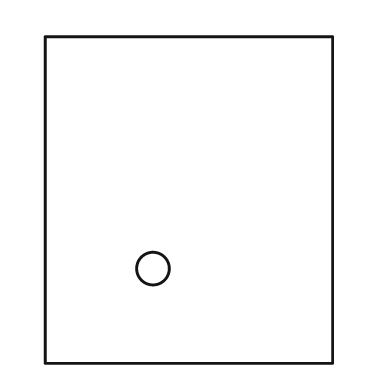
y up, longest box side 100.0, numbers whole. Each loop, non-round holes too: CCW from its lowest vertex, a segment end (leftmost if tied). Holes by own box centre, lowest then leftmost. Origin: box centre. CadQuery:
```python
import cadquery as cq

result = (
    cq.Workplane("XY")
    .moveTo(-44.0, -50.0)
    .lineTo(44.0, -50.0)
    .lineTo(44.0, 50.0)
    .lineTo(-44.0, 50.0)
    .close()
    .moveTo(-11.0, -21.0)
    .circle(5.0)
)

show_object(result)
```